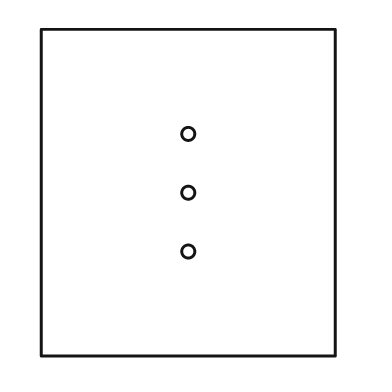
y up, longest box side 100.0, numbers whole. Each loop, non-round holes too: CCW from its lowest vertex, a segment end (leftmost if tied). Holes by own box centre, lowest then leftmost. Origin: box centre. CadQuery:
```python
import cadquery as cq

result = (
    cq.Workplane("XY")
    .moveTo(-45.0, -50.0)
    .lineTo(45.0, -50.0)
    .lineTo(45.0, 50.0)
    .lineTo(-45.0, 50.0)
    .close()
    .moveTo(0.0, -18.0)
    .circle(2.0)
    .moveTo(0.0, 0.0)
    .circle(2.0)
    .moveTo(0.0, 18.0)
    .circle(2.0)
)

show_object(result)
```